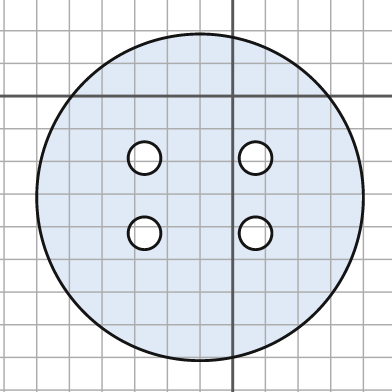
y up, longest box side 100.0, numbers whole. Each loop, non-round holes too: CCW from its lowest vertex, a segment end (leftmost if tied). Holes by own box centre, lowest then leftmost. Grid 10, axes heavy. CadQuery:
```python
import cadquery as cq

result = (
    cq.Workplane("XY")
    .moveTo(-10.0, -31.0)
    .circle(50.0)
    .moveTo(-27.0, -42.0)
    .circle(5.0)
    .moveTo(7.0, -42.0)
    .circle(5.0)
    .moveTo(-27.0, -19.0)
    .circle(5.0)
    .moveTo(7.0, -19.0)
    .circle(5.0)
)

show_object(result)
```